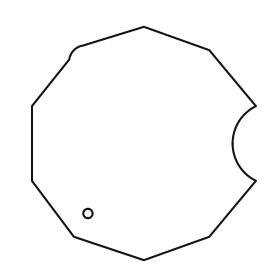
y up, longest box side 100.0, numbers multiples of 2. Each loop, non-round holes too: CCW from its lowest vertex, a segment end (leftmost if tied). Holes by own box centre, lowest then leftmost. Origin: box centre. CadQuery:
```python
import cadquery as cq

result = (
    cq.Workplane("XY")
    .moveTo(0.0, -50.0)
    .lineTo(28.0, -40.0)
    .lineTo(48.0, -16.0)
    .threePointArc((38.0, 0.0), (48.0, 16.0))
    .lineTo(28.0, 40.0)
    .lineTo(0.0, 50.0)
    .lineTo(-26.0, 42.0)
    .threePointArc((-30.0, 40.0), (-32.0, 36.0))
    .lineTo(-48.0, 16.0)
    .lineTo(-48.0, -16.0)
    .lineTo(-30.0, -40.0)
    .close()
    .moveTo(-24.0, -30.0)
    .circle(2.0)
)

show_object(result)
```